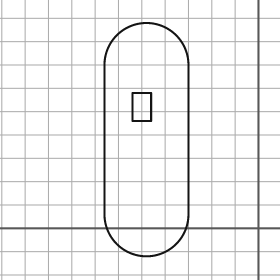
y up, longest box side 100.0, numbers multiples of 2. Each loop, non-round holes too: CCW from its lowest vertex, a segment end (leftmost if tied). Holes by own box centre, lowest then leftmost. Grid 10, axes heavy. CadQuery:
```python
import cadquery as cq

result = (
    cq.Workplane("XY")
    .moveTo(-66.0, 6.0)
    .threePointArc((-48.0, -12.0), (-30.0, 6.0))
    .lineTo(-30.0, 70.0)
    .threePointArc((-48.0, 88.0), (-66.0, 70.0))
    .close()
    .moveTo(-54.0, 46.0)
    .lineTo(-46.0, 46.0)
    .lineTo(-46.0, 58.0)
    .lineTo(-54.0, 58.0)
    .close()
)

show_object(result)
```